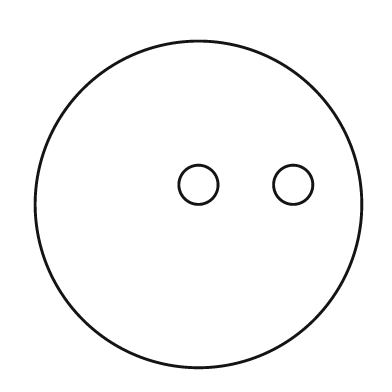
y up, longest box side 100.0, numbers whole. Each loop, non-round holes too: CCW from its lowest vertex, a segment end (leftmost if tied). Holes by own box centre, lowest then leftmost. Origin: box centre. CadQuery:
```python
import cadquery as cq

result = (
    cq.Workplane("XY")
    .moveTo(0.0, 0.0)
    .circle(50.0)
    .moveTo(0.0, 6.0)
    .circle(6.0)
    .moveTo(29.0, 6.0)
    .circle(6.0)
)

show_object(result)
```